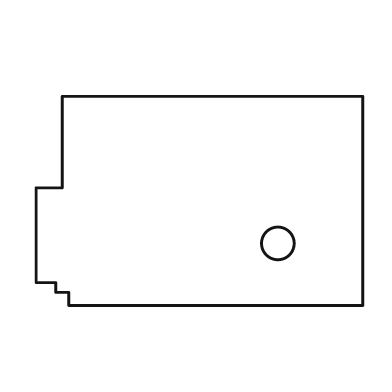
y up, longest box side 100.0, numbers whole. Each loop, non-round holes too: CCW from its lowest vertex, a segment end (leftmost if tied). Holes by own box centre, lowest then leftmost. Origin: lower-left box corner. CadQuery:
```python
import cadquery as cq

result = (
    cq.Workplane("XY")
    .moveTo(10.0, 0.0)
    .lineTo(100.0, 0.0)
    .lineTo(100.0, 64.0)
    .lineTo(8.0, 64.0)
    .lineTo(8.0, 36.0)
    .lineTo(0.0, 36.0)
    .lineTo(0.0, 7.0)
    .lineTo(6.0, 7.0)
    .lineTo(6.0, 4.0)
    .lineTo(10.0, 4.0)
    .close()
    .moveTo(74.0, 19.0)
    .circle(5.0)
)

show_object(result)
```